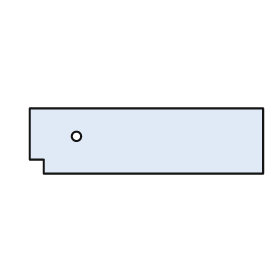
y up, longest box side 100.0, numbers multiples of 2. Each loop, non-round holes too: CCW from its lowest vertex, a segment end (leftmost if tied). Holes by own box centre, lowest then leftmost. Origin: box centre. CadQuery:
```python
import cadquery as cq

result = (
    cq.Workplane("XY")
    .moveTo(-44.0, -14.0)
    .lineTo(50.0, -14.0)
    .lineTo(50.0, 14.0)
    .lineTo(-50.0, 14.0)
    .lineTo(-50.0, -8.0)
    .lineTo(-44.0, -8.0)
    .close()
    .moveTo(-30.0, 2.0)
    .circle(2.0)
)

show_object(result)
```